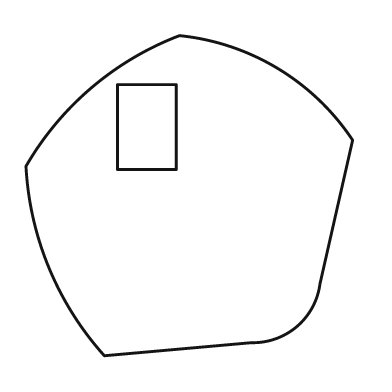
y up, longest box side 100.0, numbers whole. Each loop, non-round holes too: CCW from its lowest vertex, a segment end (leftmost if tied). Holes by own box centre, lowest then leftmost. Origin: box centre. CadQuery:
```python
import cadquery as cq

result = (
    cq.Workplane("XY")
    .moveTo(-26.0, -49.0)
    .lineTo(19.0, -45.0)
    .threePointArc((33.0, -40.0), (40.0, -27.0))
    .lineTo(50.0, 17.0)
    .threePointArc((27.0, 39.0), (-3.0, 49.0))
    .threePointArc((-30.0, 33.0), (-50.0, 9.0))
    .threePointArc((-43.0, -22.0), (-26.0, -49.0))
    .close()
    .moveTo(-22.0, 8.0)
    .lineTo(-4.0, 8.0)
    .lineTo(-4.0, 34.0)
    .lineTo(-22.0, 34.0)
    .close()
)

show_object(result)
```